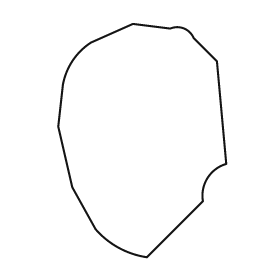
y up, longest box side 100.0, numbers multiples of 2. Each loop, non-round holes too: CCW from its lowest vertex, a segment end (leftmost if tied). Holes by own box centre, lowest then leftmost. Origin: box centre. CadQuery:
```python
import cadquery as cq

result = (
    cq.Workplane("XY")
    .moveTo(2.0, -50.0)
    .lineTo(26.0, -26.0)
    .threePointArc((28.0, -16.0), (36.0, -10.0))
    .lineTo(32.0, 34.0)
    .lineTo(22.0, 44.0)
    .threePointArc((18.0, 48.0), (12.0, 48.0))
    .lineTo(-4.0, 50.0)
    .lineTo(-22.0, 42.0)
    .threePointArc((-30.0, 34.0), (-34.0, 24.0))
    .lineTo(-36.0, 6.0)
    .lineTo(-30.0, -20.0)
    .lineTo(-20.0, -38.0)
    .threePointArc((-10.0, -46.0), (2.0, -50.0))
    .close()
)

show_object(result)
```